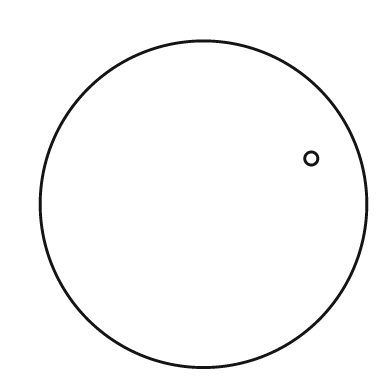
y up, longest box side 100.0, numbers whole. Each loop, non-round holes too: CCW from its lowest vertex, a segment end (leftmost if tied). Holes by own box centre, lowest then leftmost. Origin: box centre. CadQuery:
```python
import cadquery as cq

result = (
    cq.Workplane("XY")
    .moveTo(0.0, 0.0)
    .circle(50.0)
    .moveTo(33.0, 14.0)
    .circle(2.0)
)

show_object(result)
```